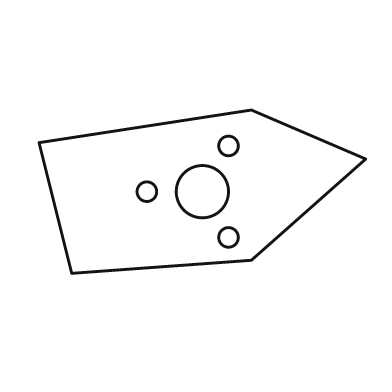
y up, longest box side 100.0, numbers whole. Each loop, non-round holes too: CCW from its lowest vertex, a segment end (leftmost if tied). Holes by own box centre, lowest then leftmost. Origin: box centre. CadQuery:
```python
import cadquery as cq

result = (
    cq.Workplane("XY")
    .moveTo(-40.0, -25.0)
    .lineTo(15.0, -21.0)
    .lineTo(50.0, 10.0)
    .lineTo(15.0, 25.0)
    .lineTo(-50.0, 15.0)
    .close()
    .moveTo(8.0, -14.0)
    .circle(3.0)
    .moveTo(-17.0, 0.0)
    .circle(3.0)
    .moveTo(0.0, 0.0)
    .circle(8.0)
    .moveTo(8.0, 14.0)
    .circle(3.0)
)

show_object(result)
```